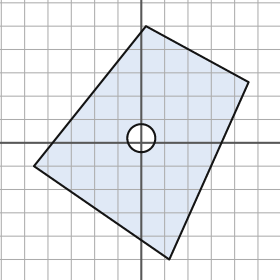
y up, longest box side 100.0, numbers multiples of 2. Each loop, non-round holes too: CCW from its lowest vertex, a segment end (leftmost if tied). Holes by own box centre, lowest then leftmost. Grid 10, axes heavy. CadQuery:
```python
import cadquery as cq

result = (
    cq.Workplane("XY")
    .moveTo(12.0, -50.0)
    .lineTo(46.0, 26.0)
    .lineTo(2.0, 50.0)
    .lineTo(-46.0, -10.0)
    .close()
    .moveTo(0.0, 2.0)
    .circle(6.0)
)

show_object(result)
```